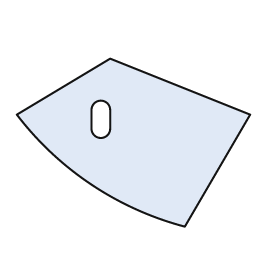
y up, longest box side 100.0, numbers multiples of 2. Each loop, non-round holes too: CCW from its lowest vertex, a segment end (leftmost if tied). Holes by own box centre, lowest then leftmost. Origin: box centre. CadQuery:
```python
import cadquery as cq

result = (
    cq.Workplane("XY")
    .moveTo(22.0, -36.0)
    .lineTo(50.0, 12.0)
    .lineTo(-10.0, 36.0)
    .lineTo(-50.0, 12.0)
    .threePointArc((-18.0, -18.0), (22.0, -36.0))
    .close()
    .moveTo(-18.0, 6.0)
    .threePointArc((-14.0, 2.0), (-10.0, 6.0))
    .lineTo(-10.0, 14.0)
    .threePointArc((-14.0, 18.0), (-18.0, 14.0))
    .close()
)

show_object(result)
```